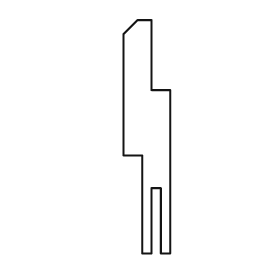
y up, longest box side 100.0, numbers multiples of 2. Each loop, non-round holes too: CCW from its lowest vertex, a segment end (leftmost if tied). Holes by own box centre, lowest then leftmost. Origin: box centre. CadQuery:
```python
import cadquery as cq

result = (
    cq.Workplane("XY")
    .moveTo(-2.0, -50.0)
    .lineTo(2.0, -50.0)
    .lineTo(2.0, -22.0)
    .lineTo(6.0, -22.0)
    .lineTo(6.0, -50.0)
    .lineTo(10.0, -50.0)
    .lineTo(10.0, 20.0)
    .lineTo(2.0, 20.0)
    .lineTo(2.0, 50.0)
    .lineTo(-4.0, 50.0)
    .lineTo(-10.0, 44.0)
    .lineTo(-10.0, -8.0)
    .lineTo(-2.0, -8.0)
    .close()
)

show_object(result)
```